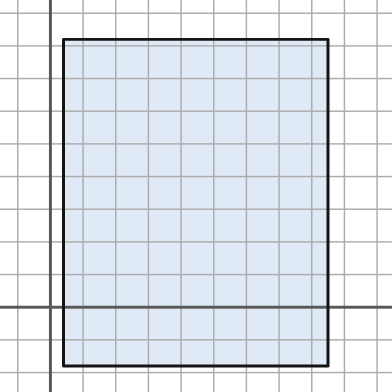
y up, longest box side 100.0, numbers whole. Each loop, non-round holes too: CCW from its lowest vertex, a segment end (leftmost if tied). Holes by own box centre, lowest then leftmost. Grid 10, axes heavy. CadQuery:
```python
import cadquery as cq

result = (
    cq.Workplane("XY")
    .moveTo(4.0, -18.0)
    .lineTo(85.0, -18.0)
    .lineTo(85.0, 82.0)
    .lineTo(4.0, 82.0)
    .close()
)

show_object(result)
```